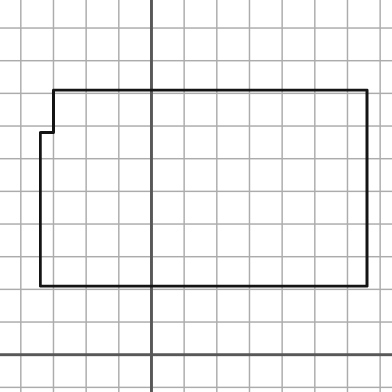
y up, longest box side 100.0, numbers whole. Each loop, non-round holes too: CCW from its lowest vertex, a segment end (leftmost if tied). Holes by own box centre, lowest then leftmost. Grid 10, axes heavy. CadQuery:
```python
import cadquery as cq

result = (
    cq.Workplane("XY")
    .moveTo(-34.0, 21.0)
    .lineTo(66.0, 21.0)
    .lineTo(66.0, 81.0)
    .lineTo(-30.0, 81.0)
    .lineTo(-30.0, 68.0)
    .lineTo(-34.0, 68.0)
    .close()
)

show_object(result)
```